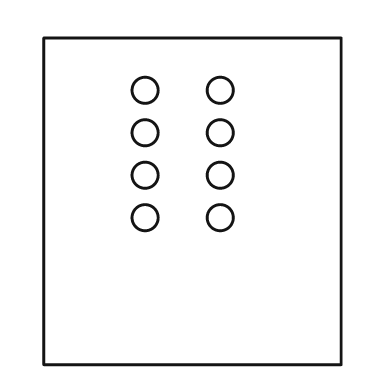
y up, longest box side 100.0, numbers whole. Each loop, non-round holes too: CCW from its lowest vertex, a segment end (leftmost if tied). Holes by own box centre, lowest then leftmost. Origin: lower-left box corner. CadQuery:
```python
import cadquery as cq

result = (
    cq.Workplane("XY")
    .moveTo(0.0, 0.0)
    .lineTo(91.0, 0.0)
    .lineTo(91.0, 100.0)
    .lineTo(0.0, 100.0)
    .close()
    .moveTo(31.0, 45.0)
    .circle(4.0)
    .moveTo(54.0, 45.0)
    .circle(4.0)
    .moveTo(31.0, 58.0)
    .circle(4.0)
    .moveTo(54.0, 58.0)
    .circle(4.0)
    .moveTo(31.0, 71.0)
    .circle(4.0)
    .moveTo(54.0, 71.0)
    .circle(4.0)
    .moveTo(31.0, 84.0)
    .circle(4.0)
    .moveTo(54.0, 84.0)
    .circle(4.0)
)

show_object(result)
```